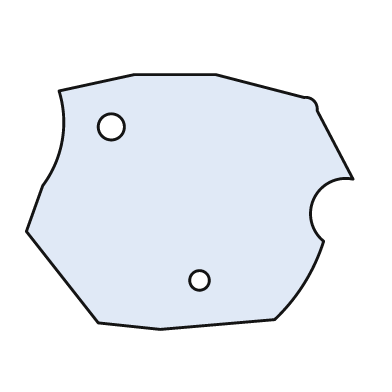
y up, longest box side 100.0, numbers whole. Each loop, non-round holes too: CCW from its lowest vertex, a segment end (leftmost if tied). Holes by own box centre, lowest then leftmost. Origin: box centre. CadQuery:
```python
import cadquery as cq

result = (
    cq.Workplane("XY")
    .moveTo(-9.0, -39.0)
    .lineTo(26.0, -36.0)
    .threePointArc((35.0, -25.0), (41.0, -12.0))
    .threePointArc((38.0, 1.0), (50.0, 7.0))
    .lineTo(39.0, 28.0)
    .threePointArc((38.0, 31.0), (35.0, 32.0))
    .lineTo(8.0, 39.0)
    .lineTo(-17.0, 39.0)
    .lineTo(-40.0, 34.0)
    .threePointArc((-39.0, 19.0), (-45.0, 5.0))
    .lineTo(-50.0, -9.0)
    .lineTo(-28.0, -37.0)
    .close()
    .moveTo(3.0, -24.0)
    .circle(3.0)
    .moveTo(-24.0, 23.0)
    .circle(4.0)
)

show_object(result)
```